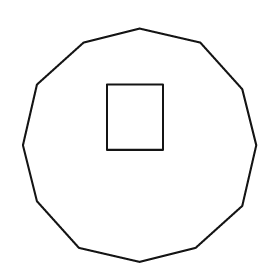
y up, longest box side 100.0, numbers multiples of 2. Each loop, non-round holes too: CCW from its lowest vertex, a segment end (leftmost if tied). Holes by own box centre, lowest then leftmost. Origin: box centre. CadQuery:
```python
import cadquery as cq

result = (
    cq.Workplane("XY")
    .moveTo(0.0, -50.0)
    .lineTo(24.0, -44.0)
    .lineTo(44.0, -26.0)
    .lineTo(50.0, 0.0)
    .lineTo(44.0, 24.0)
    .lineTo(26.0, 44.0)
    .lineTo(0.0, 50.0)
    .lineTo(-24.0, 44.0)
    .lineTo(-44.0, 26.0)
    .lineTo(-50.0, 0.0)
    .lineTo(-44.0, -24.0)
    .lineTo(-26.0, -44.0)
    .close()
    .moveTo(-14.0, -2.0)
    .lineTo(10.0, -2.0)
    .lineTo(10.0, 26.0)
    .lineTo(-14.0, 26.0)
    .close()
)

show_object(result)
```